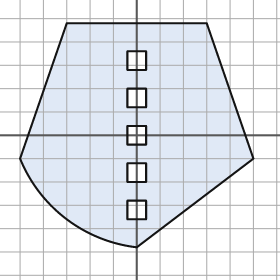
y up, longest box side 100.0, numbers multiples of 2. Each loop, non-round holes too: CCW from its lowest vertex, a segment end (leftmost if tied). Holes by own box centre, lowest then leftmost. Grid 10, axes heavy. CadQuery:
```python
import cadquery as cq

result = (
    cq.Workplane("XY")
    .moveTo(0.0, -48.0)
    .lineTo(50.0, -10.0)
    .lineTo(30.0, 48.0)
    .lineTo(-30.0, 48.0)
    .lineTo(-50.0, -10.0)
    .threePointArc((-30.0, -36.0), (0.0, -48.0))
    .close()
    .moveTo(-4.0, -36.0)
    .lineTo(4.0, -36.0)
    .lineTo(4.0, -28.0)
    .lineTo(-4.0, -28.0)
    .close()
    .moveTo(-4.0, -20.0)
    .lineTo(4.0, -20.0)
    .lineTo(4.0, -12.0)
    .lineTo(-4.0, -12.0)
    .close()
    .moveTo(-4.0, -4.0)
    .lineTo(4.0, -4.0)
    .lineTo(4.0, 4.0)
    .lineTo(-4.0, 4.0)
    .close()
    .moveTo(-4.0, 12.0)
    .lineTo(4.0, 12.0)
    .lineTo(4.0, 20.0)
    .lineTo(-4.0, 20.0)
    .close()
    .moveTo(-4.0, 28.0)
    .lineTo(4.0, 28.0)
    .lineTo(4.0, 36.0)
    .lineTo(-4.0, 36.0)
    .close()
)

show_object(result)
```